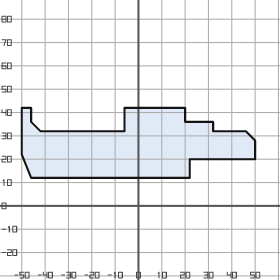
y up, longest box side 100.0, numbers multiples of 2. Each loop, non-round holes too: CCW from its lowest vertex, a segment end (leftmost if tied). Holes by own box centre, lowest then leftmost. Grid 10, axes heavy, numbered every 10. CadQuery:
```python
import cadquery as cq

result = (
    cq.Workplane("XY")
    .moveTo(-46.0, 12.0)
    .lineTo(22.0, 12.0)
    .lineTo(22.0, 20.0)
    .lineTo(50.0, 20.0)
    .lineTo(50.0, 28.0)
    .lineTo(46.0, 32.0)
    .lineTo(32.0, 32.0)
    .lineTo(32.0, 36.0)
    .lineTo(20.0, 36.0)
    .lineTo(20.0, 42.0)
    .lineTo(-6.0, 42.0)
    .lineTo(-6.0, 32.0)
    .lineTo(-42.0, 32.0)
    .lineTo(-46.0, 36.0)
    .lineTo(-46.0, 42.0)
    .lineTo(-50.0, 42.0)
    .lineTo(-50.0, 22.0)
    .close()
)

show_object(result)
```